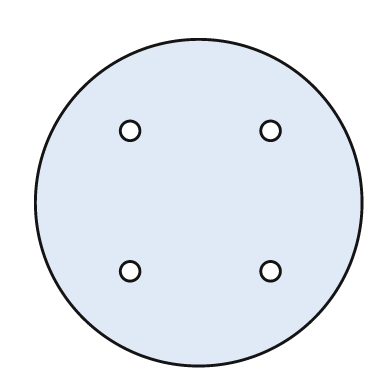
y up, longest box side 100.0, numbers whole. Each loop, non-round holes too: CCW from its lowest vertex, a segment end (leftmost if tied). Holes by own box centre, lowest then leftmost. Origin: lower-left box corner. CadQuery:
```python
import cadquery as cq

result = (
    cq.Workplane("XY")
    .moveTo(50.0, 50.0)
    .circle(50.0)
    .moveTo(29.0, 29.0)
    .circle(3.0)
    .moveTo(72.0, 29.0)
    .circle(3.0)
    .moveTo(29.0, 72.0)
    .circle(3.0)
    .moveTo(72.0, 72.0)
    .circle(3.0)
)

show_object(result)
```